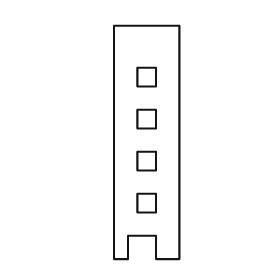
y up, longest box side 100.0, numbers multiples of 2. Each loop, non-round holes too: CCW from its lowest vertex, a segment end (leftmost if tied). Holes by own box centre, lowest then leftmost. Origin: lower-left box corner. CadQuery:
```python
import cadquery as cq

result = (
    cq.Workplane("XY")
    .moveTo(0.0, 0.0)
    .lineTo(6.0, 0.0)
    .lineTo(6.0, 10.0)
    .lineTo(18.0, 10.0)
    .lineTo(18.0, 0.0)
    .lineTo(28.0, 0.0)
    .lineTo(28.0, 100.0)
    .lineTo(0.0, 100.0)
    .close()
    .moveTo(10.0, 20.0)
    .lineTo(18.0, 20.0)
    .lineTo(18.0, 28.0)
    .lineTo(10.0, 28.0)
    .close()
    .moveTo(10.0, 38.0)
    .lineTo(18.0, 38.0)
    .lineTo(18.0, 46.0)
    .lineTo(10.0, 46.0)
    .close()
    .moveTo(10.0, 56.0)
    .lineTo(18.0, 56.0)
    .lineTo(18.0, 64.0)
    .lineTo(10.0, 64.0)
    .close()
    .moveTo(10.0, 74.0)
    .lineTo(18.0, 74.0)
    .lineTo(18.0, 82.0)
    .lineTo(10.0, 82.0)
    .close()
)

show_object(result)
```